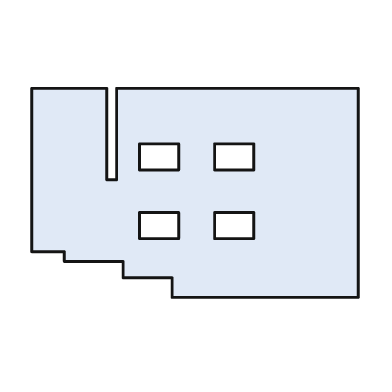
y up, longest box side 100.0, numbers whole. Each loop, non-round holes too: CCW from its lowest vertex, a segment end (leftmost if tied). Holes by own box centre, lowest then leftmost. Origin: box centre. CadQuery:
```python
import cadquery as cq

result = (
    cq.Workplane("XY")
    .moveTo(-7.0, -32.0)
    .lineTo(50.0, -32.0)
    .lineTo(50.0, 32.0)
    .lineTo(-24.0, 32.0)
    .lineTo(-24.0, 4.0)
    .lineTo(-27.0, 4.0)
    .lineTo(-27.0, 32.0)
    .lineTo(-50.0, 32.0)
    .lineTo(-50.0, -18.0)
    .lineTo(-40.0, -18.0)
    .lineTo(-40.0, -21.0)
    .lineTo(-22.0, -21.0)
    .lineTo(-22.0, -26.0)
    .lineTo(-7.0, -26.0)
    .close()
    .moveTo(-17.0, -14.0)
    .lineTo(-5.0, -14.0)
    .lineTo(-5.0, -6.0)
    .lineTo(-17.0, -6.0)
    .close()
    .moveTo(6.0, -14.0)
    .lineTo(18.0, -14.0)
    .lineTo(18.0, -6.0)
    .lineTo(6.0, -6.0)
    .close()
    .moveTo(-17.0, 7.0)
    .lineTo(-5.0, 7.0)
    .lineTo(-5.0, 15.0)
    .lineTo(-17.0, 15.0)
    .close()
    .moveTo(6.0, 7.0)
    .lineTo(18.0, 7.0)
    .lineTo(18.0, 15.0)
    .lineTo(6.0, 15.0)
    .close()
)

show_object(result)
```